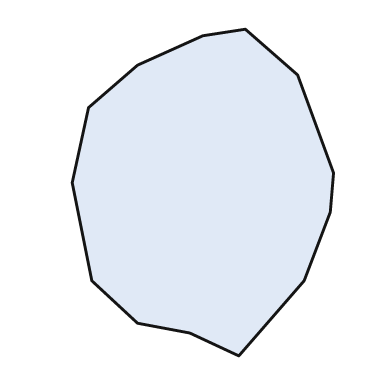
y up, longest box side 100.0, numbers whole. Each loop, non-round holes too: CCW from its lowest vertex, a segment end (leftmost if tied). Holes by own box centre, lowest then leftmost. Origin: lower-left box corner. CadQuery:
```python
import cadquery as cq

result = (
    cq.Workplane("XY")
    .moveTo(51.0, 0.0)
    .lineTo(71.0, 23.0)
    .lineTo(79.0, 44.0)
    .lineTo(80.0, 56.0)
    .lineTo(69.0, 86.0)
    .lineTo(53.0, 100.0)
    .lineTo(40.0, 98.0)
    .lineTo(20.0, 89.0)
    .lineTo(5.0, 76.0)
    .lineTo(0.0, 53.0)
    .lineTo(6.0, 23.0)
    .lineTo(20.0, 10.0)
    .lineTo(36.0, 7.0)
    .close()
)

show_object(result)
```